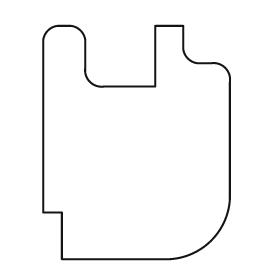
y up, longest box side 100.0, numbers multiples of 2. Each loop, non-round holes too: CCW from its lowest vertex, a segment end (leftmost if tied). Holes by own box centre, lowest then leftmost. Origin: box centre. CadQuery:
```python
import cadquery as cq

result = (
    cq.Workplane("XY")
    .moveTo(-32.0, -50.0)
    .lineTo(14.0, -50.0)
    .threePointArc((32.0, -42.0), (40.0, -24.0))
    .lineTo(40.0, 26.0)
    .threePointArc((38.0, 32.0), (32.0, 34.0))
    .lineTo(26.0, 34.0)
    .threePointArc((22.0, 36.0), (20.0, 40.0))
    .lineTo(20.0, 50.0)
    .lineTo(8.0, 50.0)
    .lineTo(8.0, 24.0)
    .lineTo(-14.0, 24.0)
    .threePointArc((-20.0, 26.0), (-22.0, 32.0))
    .lineTo(-22.0, 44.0)
    .threePointArc((-24.0, 48.0), (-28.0, 50.0))
    .lineTo(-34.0, 50.0)
    .threePointArc((-38.0, 48.0), (-40.0, 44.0))
    .lineTo(-40.0, -30.0)
    .lineTo(-32.0, -30.0)
    .close()
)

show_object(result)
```